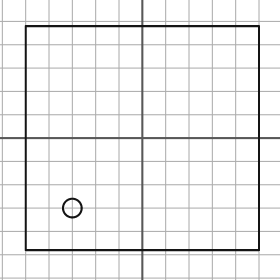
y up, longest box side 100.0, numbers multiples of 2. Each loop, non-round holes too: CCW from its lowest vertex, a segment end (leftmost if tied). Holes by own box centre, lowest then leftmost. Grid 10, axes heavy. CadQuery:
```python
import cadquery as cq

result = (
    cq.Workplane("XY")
    .moveTo(-50.0, -48.0)
    .lineTo(50.0, -48.0)
    .lineTo(50.0, 48.0)
    .lineTo(-50.0, 48.0)
    .close()
    .moveTo(-30.0, -30.0)
    .circle(4.0)
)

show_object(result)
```